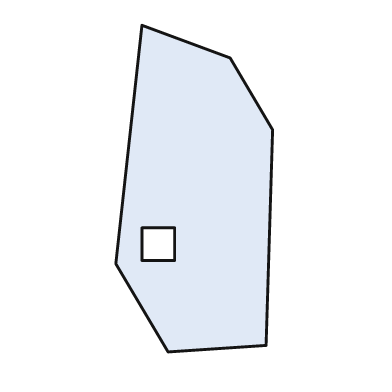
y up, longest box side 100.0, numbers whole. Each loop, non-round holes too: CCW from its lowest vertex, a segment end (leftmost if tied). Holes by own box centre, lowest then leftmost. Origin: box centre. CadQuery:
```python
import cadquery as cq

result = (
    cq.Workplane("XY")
    .moveTo(-8.0, -50.0)
    .lineTo(22.0, -48.0)
    .lineTo(24.0, 18.0)
    .lineTo(11.0, 40.0)
    .lineTo(-16.0, 50.0)
    .lineTo(-24.0, -23.0)
    .close()
    .moveTo(-16.0, -22.0)
    .lineTo(-6.0, -22.0)
    .lineTo(-6.0, -12.0)
    .lineTo(-16.0, -12.0)
    .close()
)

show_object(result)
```